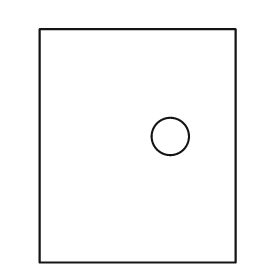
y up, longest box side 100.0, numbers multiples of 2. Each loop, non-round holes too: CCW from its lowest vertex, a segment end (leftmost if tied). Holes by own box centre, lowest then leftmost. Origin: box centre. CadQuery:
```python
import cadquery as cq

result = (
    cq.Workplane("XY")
    .moveTo(-42.0, -50.0)
    .lineTo(42.0, -50.0)
    .lineTo(42.0, 50.0)
    .lineTo(-42.0, 50.0)
    .close()
    .moveTo(14.0, 4.0)
    .circle(8.0)
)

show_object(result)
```